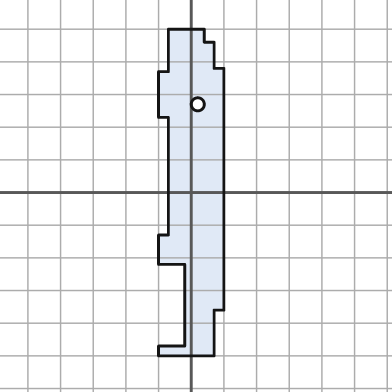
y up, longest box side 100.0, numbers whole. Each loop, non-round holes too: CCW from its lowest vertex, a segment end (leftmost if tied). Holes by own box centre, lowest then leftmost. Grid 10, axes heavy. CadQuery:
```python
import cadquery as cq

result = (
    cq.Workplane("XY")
    .moveTo(-10.0, -50.0)
    .lineTo(7.0, -50.0)
    .lineTo(7.0, -36.0)
    .lineTo(10.0, -36.0)
    .lineTo(10.0, 38.0)
    .lineTo(7.0, 38.0)
    .lineTo(7.0, 46.0)
    .lineTo(4.0, 46.0)
    .lineTo(4.0, 50.0)
    .lineTo(-7.0, 50.0)
    .lineTo(-7.0, 37.0)
    .lineTo(-10.0, 37.0)
    .lineTo(-10.0, 23.0)
    .lineTo(-7.0, 23.0)
    .lineTo(-7.0, -13.0)
    .lineTo(-10.0, -13.0)
    .lineTo(-10.0, -22.0)
    .lineTo(-2.0, -22.0)
    .lineTo(-2.0, -47.0)
    .lineTo(-10.0, -47.0)
    .close()
    .moveTo(2.0, 27.0)
    .circle(2.0)
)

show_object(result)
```